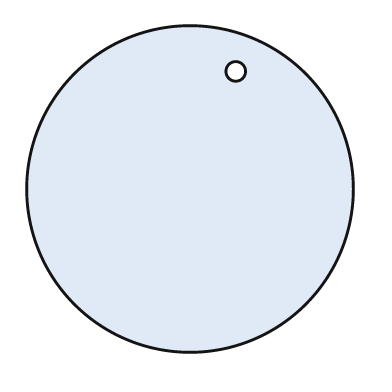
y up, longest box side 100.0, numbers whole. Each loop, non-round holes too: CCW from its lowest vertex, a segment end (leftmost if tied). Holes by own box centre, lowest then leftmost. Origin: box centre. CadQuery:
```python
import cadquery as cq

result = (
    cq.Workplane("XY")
    .moveTo(0.0, 0.0)
    .circle(50.0)
    .moveTo(14.0, 36.0)
    .circle(3.0)
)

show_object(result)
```